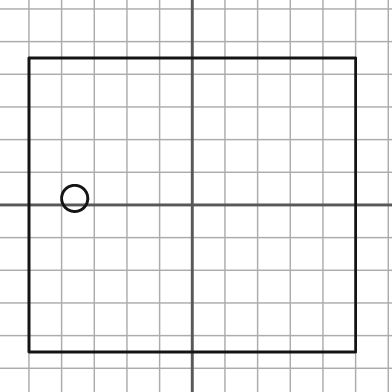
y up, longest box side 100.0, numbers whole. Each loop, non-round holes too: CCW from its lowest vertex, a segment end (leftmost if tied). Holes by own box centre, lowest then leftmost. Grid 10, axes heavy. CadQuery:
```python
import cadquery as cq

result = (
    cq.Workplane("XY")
    .moveTo(-50.0, -45.0)
    .lineTo(50.0, -45.0)
    .lineTo(50.0, 45.0)
    .lineTo(-50.0, 45.0)
    .close()
    .moveTo(-36.0, 2.0)
    .circle(4.0)
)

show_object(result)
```